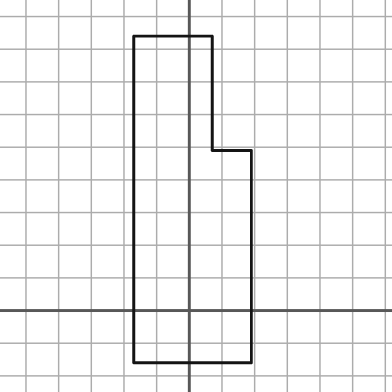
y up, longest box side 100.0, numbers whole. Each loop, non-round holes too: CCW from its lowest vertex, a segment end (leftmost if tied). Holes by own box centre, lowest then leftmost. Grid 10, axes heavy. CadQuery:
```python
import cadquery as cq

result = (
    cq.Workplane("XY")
    .moveTo(-17.0, -16.0)
    .lineTo(19.0, -16.0)
    .lineTo(19.0, 49.0)
    .lineTo(7.0, 49.0)
    .lineTo(7.0, 84.0)
    .lineTo(-17.0, 84.0)
    .close()
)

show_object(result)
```